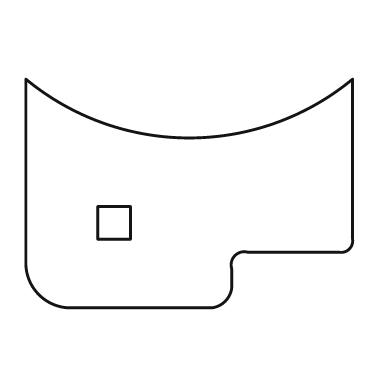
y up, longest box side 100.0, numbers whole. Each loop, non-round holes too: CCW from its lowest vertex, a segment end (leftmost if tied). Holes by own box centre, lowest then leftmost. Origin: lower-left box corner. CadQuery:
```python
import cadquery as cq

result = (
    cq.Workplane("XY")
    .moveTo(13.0, 0.0)
    .lineTo(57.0, 0.0)
    .threePointArc((61.0, 2.0), (63.0, 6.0))
    .lineTo(63.0, 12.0)
    .threePointArc((64.0, 16.0), (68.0, 17.0))
    .lineTo(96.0, 17.0)
    .threePointArc((99.0, 18.0), (100.0, 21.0))
    .lineTo(100.0, 70.0)
    .threePointArc((50.0, 52.0), (0.0, 70.0))
    .lineTo(0.0, 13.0)
    .threePointArc((4.0, 4.0), (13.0, 0.0))
    .close()
    .moveTo(22.0, 21.0)
    .lineTo(32.0, 21.0)
    .lineTo(32.0, 31.0)
    .lineTo(22.0, 31.0)
    .close()
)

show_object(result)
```